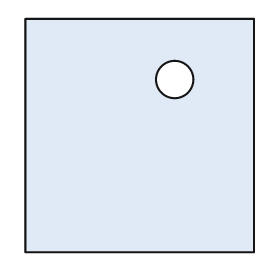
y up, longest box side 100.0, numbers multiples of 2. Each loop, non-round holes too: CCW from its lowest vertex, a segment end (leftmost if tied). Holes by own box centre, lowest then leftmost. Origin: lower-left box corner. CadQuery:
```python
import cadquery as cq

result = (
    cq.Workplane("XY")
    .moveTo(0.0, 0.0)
    .lineTo(98.0, 0.0)
    .lineTo(98.0, 100.0)
    .lineTo(0.0, 100.0)
    .close()
    .moveTo(64.0, 74.0)
    .circle(8.0)
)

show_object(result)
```